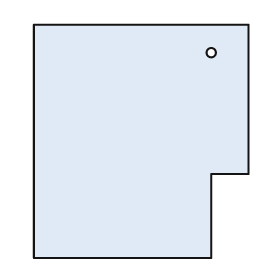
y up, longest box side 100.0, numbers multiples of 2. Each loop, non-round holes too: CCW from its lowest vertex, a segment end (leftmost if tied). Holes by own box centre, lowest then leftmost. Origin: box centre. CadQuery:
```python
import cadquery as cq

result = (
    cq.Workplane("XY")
    .moveTo(-46.0, -50.0)
    .lineTo(30.0, -50.0)
    .lineTo(30.0, -14.0)
    .lineTo(46.0, -14.0)
    .lineTo(46.0, 50.0)
    .lineTo(-46.0, 50.0)
    .close()
    .moveTo(30.0, 38.0)
    .circle(2.0)
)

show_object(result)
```